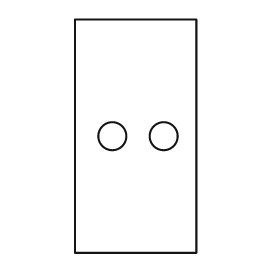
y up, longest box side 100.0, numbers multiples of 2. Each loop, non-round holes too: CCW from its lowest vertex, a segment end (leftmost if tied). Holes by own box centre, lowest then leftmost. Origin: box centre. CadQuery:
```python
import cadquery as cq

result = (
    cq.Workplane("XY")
    .moveTo(-26.0, -50.0)
    .lineTo(26.0, -50.0)
    .lineTo(26.0, 50.0)
    .lineTo(-26.0, 50.0)
    .close()
    .moveTo(-10.0, 0.0)
    .circle(6.0)
    .moveTo(12.0, 0.0)
    .circle(6.0)
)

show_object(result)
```